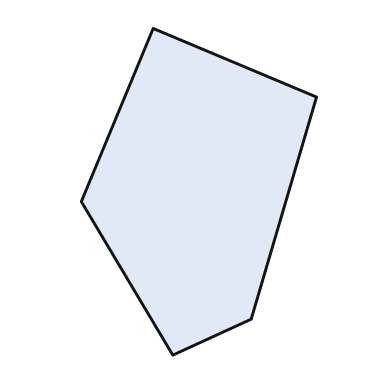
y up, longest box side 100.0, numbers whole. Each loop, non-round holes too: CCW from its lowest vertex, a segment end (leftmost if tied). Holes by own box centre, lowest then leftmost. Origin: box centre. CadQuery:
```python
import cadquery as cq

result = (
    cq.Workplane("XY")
    .moveTo(-8.0, -50.0)
    .lineTo(16.0, -39.0)
    .lineTo(36.0, 29.0)
    .lineTo(-14.0, 50.0)
    .lineTo(-36.0, -3.0)
    .close()
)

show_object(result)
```